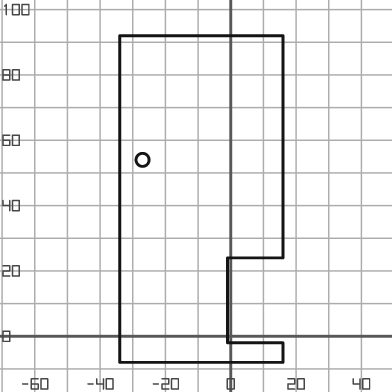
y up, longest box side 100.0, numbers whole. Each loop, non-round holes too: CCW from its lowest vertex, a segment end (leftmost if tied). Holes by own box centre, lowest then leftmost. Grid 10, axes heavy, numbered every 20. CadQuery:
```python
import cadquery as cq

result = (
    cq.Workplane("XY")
    .moveTo(-34.0, -8.0)
    .lineTo(16.0, -8.0)
    .lineTo(16.0, -2.0)
    .lineTo(-1.0, -2.0)
    .lineTo(-1.0, 24.0)
    .lineTo(16.0, 24.0)
    .lineTo(16.0, 92.0)
    .lineTo(-34.0, 92.0)
    .close()
    .moveTo(-27.0, 54.0)
    .circle(2.0)
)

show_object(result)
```